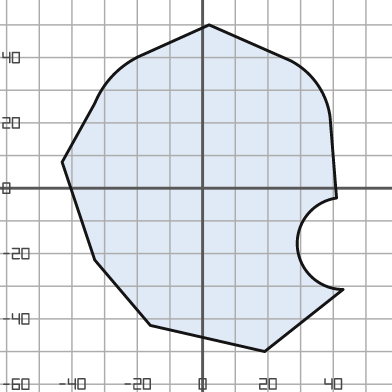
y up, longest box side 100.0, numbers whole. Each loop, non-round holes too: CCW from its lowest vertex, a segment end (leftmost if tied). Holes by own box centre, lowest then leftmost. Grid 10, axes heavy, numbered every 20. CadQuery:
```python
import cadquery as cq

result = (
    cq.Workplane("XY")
    .moveTo(19.0, -50.0)
    .lineTo(43.0, -31.0)
    .threePointArc((29.0, -18.0), (41.0, -3.0))
    .lineTo(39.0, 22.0)
    .threePointArc((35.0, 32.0), (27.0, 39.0))
    .lineTo(2.0, 50.0)
    .lineTo(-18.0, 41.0)
    .threePointArc((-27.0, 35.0), (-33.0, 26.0))
    .lineTo(-43.0, 8.0)
    .lineTo(-33.0, -22.0)
    .lineTo(-16.0, -42.0)
    .close()
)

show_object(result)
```